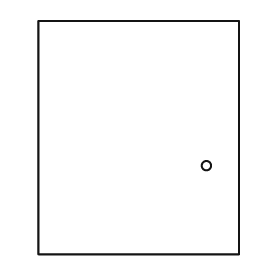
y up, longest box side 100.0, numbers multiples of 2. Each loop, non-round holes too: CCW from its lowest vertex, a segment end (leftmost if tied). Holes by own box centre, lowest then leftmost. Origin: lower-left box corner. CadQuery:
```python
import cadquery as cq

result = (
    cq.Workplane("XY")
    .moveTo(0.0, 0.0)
    .lineTo(86.0, 0.0)
    .lineTo(86.0, 100.0)
    .lineTo(0.0, 100.0)
    .close()
    .moveTo(72.0, 38.0)
    .circle(2.0)
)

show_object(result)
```